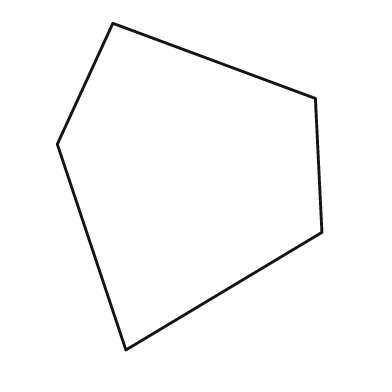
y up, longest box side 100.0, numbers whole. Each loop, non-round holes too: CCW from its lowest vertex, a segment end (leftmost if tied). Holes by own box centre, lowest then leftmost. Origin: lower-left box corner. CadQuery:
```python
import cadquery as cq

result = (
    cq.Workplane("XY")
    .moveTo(21.0, 0.0)
    .lineTo(81.0, 36.0)
    .lineTo(79.0, 77.0)
    .lineTo(17.0, 100.0)
    .lineTo(0.0, 63.0)
    .close()
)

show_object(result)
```